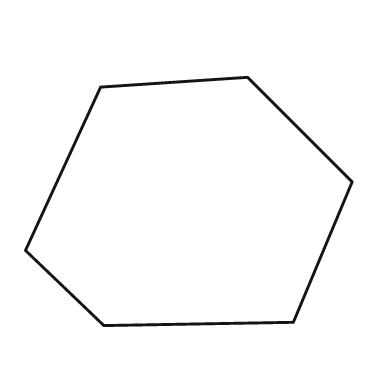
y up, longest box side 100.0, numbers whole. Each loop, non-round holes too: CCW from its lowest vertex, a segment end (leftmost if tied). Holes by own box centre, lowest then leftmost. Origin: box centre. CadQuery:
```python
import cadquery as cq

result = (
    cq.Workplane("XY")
    .moveTo(-26.0, -38.0)
    .lineTo(32.0, -37.0)
    .lineTo(50.0, 6.0)
    .lineTo(18.0, 38.0)
    .lineTo(-27.0, 35.0)
    .lineTo(-50.0, -15.0)
    .close()
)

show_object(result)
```